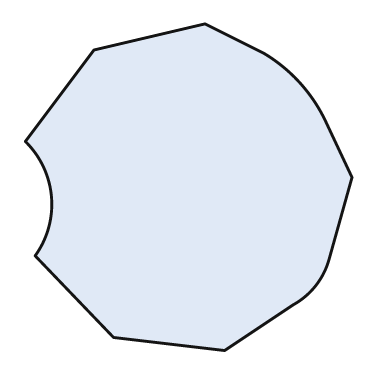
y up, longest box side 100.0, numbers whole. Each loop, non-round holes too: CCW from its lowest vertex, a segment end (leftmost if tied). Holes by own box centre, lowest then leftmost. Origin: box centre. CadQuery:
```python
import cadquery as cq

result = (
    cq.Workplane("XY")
    .moveTo(11.0, -50.0)
    .lineTo(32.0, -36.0)
    .threePointArc((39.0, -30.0), (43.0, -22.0))
    .lineTo(50.0, 3.0)
    .lineTo(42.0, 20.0)
    .threePointArc((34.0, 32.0), (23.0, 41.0))
    .lineTo(5.0, 50.0)
    .lineTo(-29.0, 42.0)
    .lineTo(-50.0, 14.0)
    .threePointArc((-42.0, -3.0), (-47.0, -21.0))
    .lineTo(-23.0, -46.0)
    .close()
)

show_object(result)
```